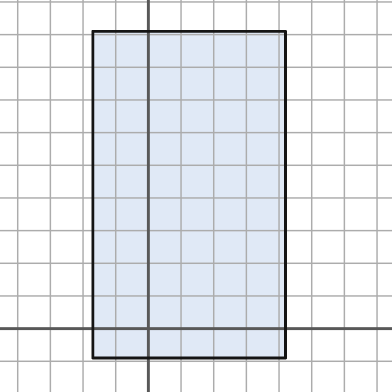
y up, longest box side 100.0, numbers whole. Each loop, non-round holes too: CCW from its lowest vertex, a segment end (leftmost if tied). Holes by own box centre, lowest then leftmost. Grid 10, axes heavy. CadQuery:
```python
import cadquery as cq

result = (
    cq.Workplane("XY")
    .moveTo(-17.0, -9.0)
    .lineTo(42.0, -9.0)
    .lineTo(42.0, 91.0)
    .lineTo(-17.0, 91.0)
    .close()
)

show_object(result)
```